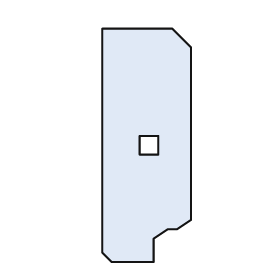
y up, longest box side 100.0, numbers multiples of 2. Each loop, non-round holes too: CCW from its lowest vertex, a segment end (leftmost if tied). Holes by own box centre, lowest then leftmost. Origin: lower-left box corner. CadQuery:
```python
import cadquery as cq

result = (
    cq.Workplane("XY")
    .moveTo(4.0, 0.0)
    .lineTo(22.0, 0.0)
    .lineTo(22.0, 10.0)
    .lineTo(28.0, 14.0)
    .lineTo(32.0, 14.0)
    .lineTo(38.0, 18.0)
    .lineTo(38.0, 92.0)
    .lineTo(30.0, 100.0)
    .lineTo(0.0, 100.0)
    .lineTo(0.0, 4.0)
    .close()
    .moveTo(16.0, 46.0)
    .lineTo(24.0, 46.0)
    .lineTo(24.0, 54.0)
    .lineTo(16.0, 54.0)
    .close()
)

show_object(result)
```